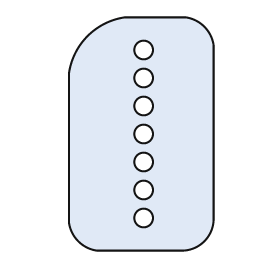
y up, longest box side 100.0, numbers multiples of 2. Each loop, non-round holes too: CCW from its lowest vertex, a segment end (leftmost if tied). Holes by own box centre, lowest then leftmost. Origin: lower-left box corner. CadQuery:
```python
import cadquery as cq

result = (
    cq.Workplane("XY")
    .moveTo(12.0, 0.0)
    .lineTo(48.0, 0.0)
    .threePointArc((58.0, 4.0), (62.0, 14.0))
    .lineTo(62.0, 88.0)
    .threePointArc((58.0, 96.0), (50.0, 100.0))
    .lineTo(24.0, 100.0)
    .threePointArc((8.0, 92.0), (0.0, 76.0))
    .lineTo(0.0, 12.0)
    .threePointArc((4.0, 4.0), (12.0, 0.0))
    .close()
    .moveTo(32.0, 14.0)
    .circle(4.0)
    .moveTo(32.0, 26.0)
    .circle(4.0)
    .moveTo(32.0, 38.0)
    .circle(4.0)
    .moveTo(32.0, 50.0)
    .circle(4.0)
    .moveTo(32.0, 62.0)
    .circle(4.0)
    .moveTo(32.0, 74.0)
    .circle(4.0)
    .moveTo(32.0, 86.0)
    .circle(4.0)
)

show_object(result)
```